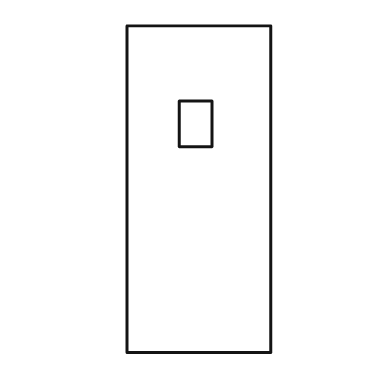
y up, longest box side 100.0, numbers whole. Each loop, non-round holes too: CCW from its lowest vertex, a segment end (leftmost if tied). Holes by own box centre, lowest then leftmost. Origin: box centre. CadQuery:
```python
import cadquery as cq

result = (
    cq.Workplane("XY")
    .moveTo(-22.0, -50.0)
    .lineTo(22.0, -50.0)
    .lineTo(22.0, 50.0)
    .lineTo(-22.0, 50.0)
    .close()
    .moveTo(-6.0, 13.0)
    .lineTo(4.0, 13.0)
    .lineTo(4.0, 27.0)
    .lineTo(-6.0, 27.0)
    .close()
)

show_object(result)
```